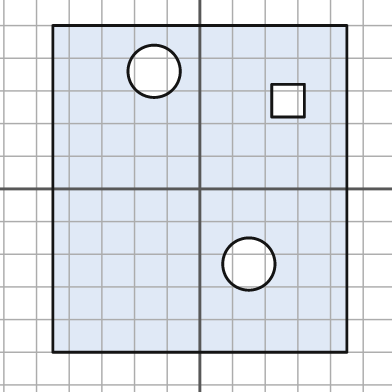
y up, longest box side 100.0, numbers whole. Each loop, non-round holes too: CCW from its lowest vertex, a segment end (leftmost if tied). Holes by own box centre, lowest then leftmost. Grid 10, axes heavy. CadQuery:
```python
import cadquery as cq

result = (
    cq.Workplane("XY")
    .moveTo(-45.0, -50.0)
    .lineTo(45.0, -50.0)
    .lineTo(45.0, 50.0)
    .lineTo(-45.0, 50.0)
    .close()
    .moveTo(15.0, -23.0)
    .circle(8.0)
    .moveTo(22.0, 22.0)
    .lineTo(32.0, 22.0)
    .lineTo(32.0, 32.0)
    .lineTo(22.0, 32.0)
    .close()
    .moveTo(-14.0, 36.0)
    .circle(8.0)
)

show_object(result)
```